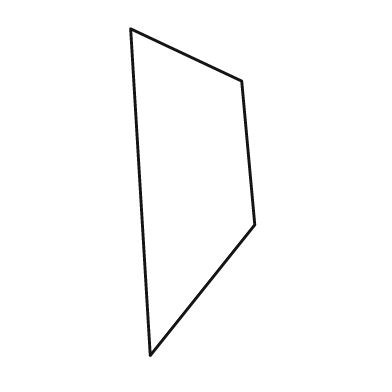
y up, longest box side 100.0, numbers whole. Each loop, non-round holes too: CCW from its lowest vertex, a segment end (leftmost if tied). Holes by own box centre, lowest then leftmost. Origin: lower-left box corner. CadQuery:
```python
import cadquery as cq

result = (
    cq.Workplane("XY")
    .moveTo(6.0, 0.0)
    .lineTo(38.0, 40.0)
    .lineTo(34.0, 84.0)
    .lineTo(0.0, 100.0)
    .close()
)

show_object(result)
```